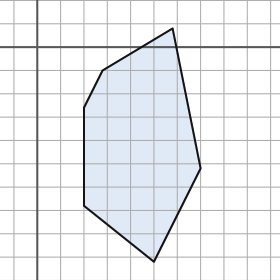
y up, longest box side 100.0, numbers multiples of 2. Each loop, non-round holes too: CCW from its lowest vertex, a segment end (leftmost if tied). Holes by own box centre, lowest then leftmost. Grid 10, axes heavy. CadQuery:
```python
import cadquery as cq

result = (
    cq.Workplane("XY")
    .moveTo(50.0, -92.0)
    .lineTo(70.0, -52.0)
    .lineTo(58.0, 8.0)
    .lineTo(28.0, -10.0)
    .lineTo(20.0, -26.0)
    .lineTo(20.0, -68.0)
    .close()
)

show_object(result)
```